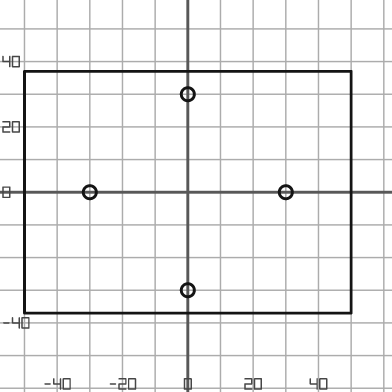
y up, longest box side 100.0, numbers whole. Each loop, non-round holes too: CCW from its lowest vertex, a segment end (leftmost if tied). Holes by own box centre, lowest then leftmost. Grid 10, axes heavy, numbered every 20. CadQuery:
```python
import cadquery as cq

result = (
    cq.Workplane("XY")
    .moveTo(-50.0, -37.0)
    .lineTo(50.0, -37.0)
    .lineTo(50.0, 37.0)
    .lineTo(-50.0, 37.0)
    .close()
    .moveTo(0.0, -30.0)
    .circle(2.0)
    .moveTo(-30.0, 0.0)
    .circle(2.0)
    .moveTo(30.0, 0.0)
    .circle(2.0)
    .moveTo(0.0, 30.0)
    .circle(2.0)
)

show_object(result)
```